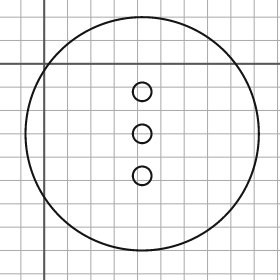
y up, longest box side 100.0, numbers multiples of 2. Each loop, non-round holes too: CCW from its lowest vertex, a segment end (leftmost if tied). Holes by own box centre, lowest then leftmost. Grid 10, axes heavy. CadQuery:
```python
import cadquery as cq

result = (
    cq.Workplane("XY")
    .moveTo(42.0, -30.0)
    .circle(50.0)
    .moveTo(42.0, -48.0)
    .circle(4.0)
    .moveTo(42.0, -30.0)
    .circle(4.0)
    .moveTo(42.0, -12.0)
    .circle(4.0)
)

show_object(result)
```